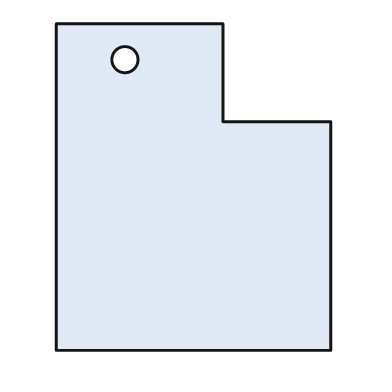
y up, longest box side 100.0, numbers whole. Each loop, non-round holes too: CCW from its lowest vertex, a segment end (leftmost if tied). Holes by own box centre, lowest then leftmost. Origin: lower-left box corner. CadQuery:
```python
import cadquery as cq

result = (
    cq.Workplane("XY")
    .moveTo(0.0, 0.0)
    .lineTo(84.0, 0.0)
    .lineTo(84.0, 70.0)
    .lineTo(51.0, 70.0)
    .lineTo(51.0, 100.0)
    .lineTo(0.0, 100.0)
    .close()
    .moveTo(21.0, 89.0)
    .circle(4.0)
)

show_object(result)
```